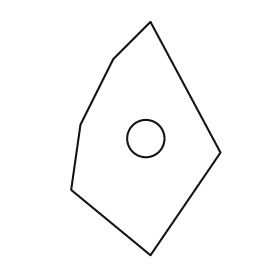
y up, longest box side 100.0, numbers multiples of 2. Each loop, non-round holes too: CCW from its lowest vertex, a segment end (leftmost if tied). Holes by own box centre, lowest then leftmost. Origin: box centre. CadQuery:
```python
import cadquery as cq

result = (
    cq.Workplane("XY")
    .moveTo(2.0, -50.0)
    .lineTo(32.0, -6.0)
    .lineTo(2.0, 50.0)
    .lineTo(-14.0, 34.0)
    .lineTo(-28.0, 6.0)
    .lineTo(-32.0, -22.0)
    .close()
    .moveTo(0.0, 0.0)
    .circle(8.0)
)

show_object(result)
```